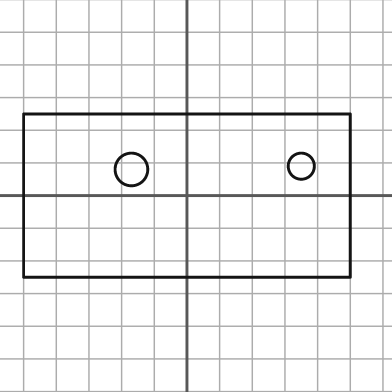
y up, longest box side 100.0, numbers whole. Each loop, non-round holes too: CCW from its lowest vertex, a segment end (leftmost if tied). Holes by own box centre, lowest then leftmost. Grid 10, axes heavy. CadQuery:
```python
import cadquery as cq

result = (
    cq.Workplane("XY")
    .moveTo(-50.0, -25.0)
    .lineTo(50.0, -25.0)
    .lineTo(50.0, 25.0)
    .lineTo(-50.0, 25.0)
    .close()
    .moveTo(-17.0, 8.0)
    .circle(5.0)
    .moveTo(35.0, 9.0)
    .circle(4.0)
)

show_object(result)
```